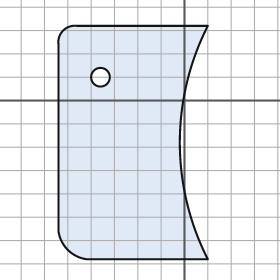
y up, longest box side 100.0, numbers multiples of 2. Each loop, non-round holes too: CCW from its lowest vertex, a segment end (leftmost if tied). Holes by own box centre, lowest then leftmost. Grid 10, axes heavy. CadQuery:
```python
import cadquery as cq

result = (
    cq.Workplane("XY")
    .moveTo(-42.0, -68.0)
    .lineTo(10.0, -68.0)
    .threePointArc((-2.0, -18.0), (10.0, 32.0))
    .lineTo(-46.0, 32.0)
    .threePointArc((-52.0, 30.0), (-54.0, 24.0))
    .lineTo(-54.0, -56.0)
    .threePointArc((-50.0, -64.0), (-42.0, -68.0))
    .close()
    .moveTo(-36.0, 10.0)
    .circle(4.0)
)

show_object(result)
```